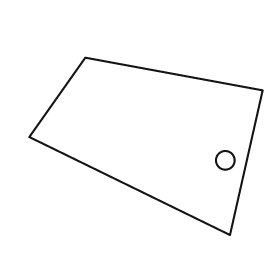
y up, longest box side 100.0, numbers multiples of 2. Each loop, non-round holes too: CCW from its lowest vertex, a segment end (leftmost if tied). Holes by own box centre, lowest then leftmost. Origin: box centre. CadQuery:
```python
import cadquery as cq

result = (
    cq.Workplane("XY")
    .moveTo(36.0, -38.0)
    .lineTo(50.0, 24.0)
    .lineTo(-26.0, 38.0)
    .lineTo(-50.0, 4.0)
    .close()
    .moveTo(34.0, -6.0)
    .circle(4.0)
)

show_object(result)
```